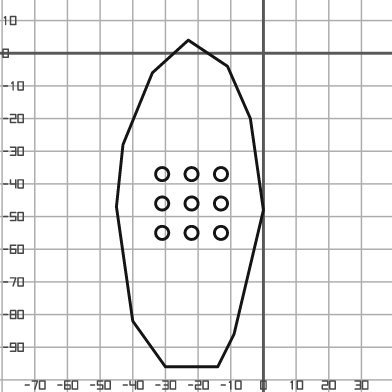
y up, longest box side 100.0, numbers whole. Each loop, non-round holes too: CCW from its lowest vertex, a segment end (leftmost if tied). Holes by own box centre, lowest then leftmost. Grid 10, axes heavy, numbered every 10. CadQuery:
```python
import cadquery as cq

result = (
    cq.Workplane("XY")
    .moveTo(-30.0, -96.0)
    .lineTo(-14.0, -96.0)
    .lineTo(-9.0, -86.0)
    .lineTo(0.0, -48.0)
    .lineTo(-4.0, -20.0)
    .lineTo(-11.0, -4.0)
    .lineTo(-23.0, 4.0)
    .lineTo(-34.0, -6.0)
    .lineTo(-43.0, -28.0)
    .lineTo(-45.0, -47.0)
    .lineTo(-40.0, -82.0)
    .close()
    .moveTo(-31.0, -55.0)
    .circle(2.0)
    .moveTo(-22.0, -55.0)
    .circle(2.0)
    .moveTo(-13.0, -55.0)
    .circle(2.0)
    .moveTo(-31.0, -46.0)
    .circle(2.0)
    .moveTo(-22.0, -46.0)
    .circle(2.0)
    .moveTo(-13.0, -46.0)
    .circle(2.0)
    .moveTo(-31.0, -37.0)
    .circle(2.0)
    .moveTo(-22.0, -37.0)
    .circle(2.0)
    .moveTo(-13.0, -37.0)
    .circle(2.0)
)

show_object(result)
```